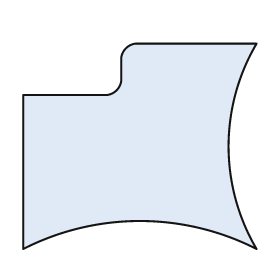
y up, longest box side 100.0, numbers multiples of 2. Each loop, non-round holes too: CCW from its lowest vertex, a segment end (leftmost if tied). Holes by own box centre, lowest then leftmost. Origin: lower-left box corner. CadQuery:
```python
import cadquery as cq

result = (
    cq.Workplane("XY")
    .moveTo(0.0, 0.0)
    .threePointArc((50.0, 12.0), (100.0, 0.0))
    .threePointArc((88.0, 44.0), (100.0, 88.0))
    .lineTo(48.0, 88.0)
    .threePointArc((44.0, 86.0), (42.0, 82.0))
    .lineTo(42.0, 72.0)
    .threePointArc((40.0, 68.0), (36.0, 66.0))
    .lineTo(0.0, 66.0)
    .close()
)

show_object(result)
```